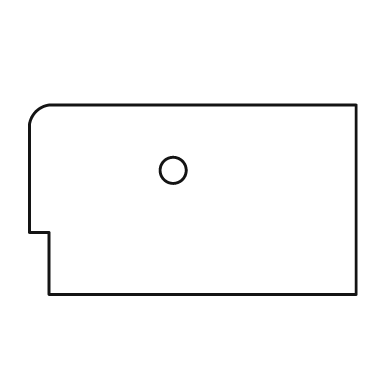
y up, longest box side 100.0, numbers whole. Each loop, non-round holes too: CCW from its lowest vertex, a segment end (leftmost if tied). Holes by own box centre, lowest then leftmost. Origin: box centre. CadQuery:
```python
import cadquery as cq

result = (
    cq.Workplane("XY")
    .moveTo(-44.0, -29.0)
    .lineTo(50.0, -29.0)
    .lineTo(50.0, 29.0)
    .lineTo(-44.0, 29.0)
    .threePointArc((-48.0, 27.0), (-50.0, 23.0))
    .lineTo(-50.0, -10.0)
    .lineTo(-44.0, -10.0)
    .close()
    .moveTo(-6.0, 9.0)
    .circle(4.0)
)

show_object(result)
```